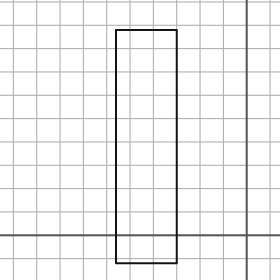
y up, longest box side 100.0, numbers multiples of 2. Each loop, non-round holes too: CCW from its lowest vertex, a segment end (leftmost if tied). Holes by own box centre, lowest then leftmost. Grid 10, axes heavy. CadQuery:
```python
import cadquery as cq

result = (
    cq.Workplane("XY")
    .moveTo(-56.0, -12.0)
    .lineTo(-30.0, -12.0)
    .lineTo(-30.0, 88.0)
    .lineTo(-56.0, 88.0)
    .close()
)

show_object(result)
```